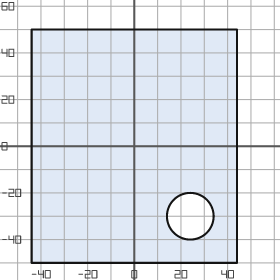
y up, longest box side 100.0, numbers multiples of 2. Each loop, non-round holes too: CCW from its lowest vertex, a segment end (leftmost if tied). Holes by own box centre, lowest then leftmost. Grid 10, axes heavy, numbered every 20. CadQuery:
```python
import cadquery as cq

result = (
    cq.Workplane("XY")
    .moveTo(-44.0, -50.0)
    .lineTo(44.0, -50.0)
    .lineTo(44.0, 50.0)
    .lineTo(-44.0, 50.0)
    .close()
    .moveTo(24.0, -30.0)
    .circle(10.0)
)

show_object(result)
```